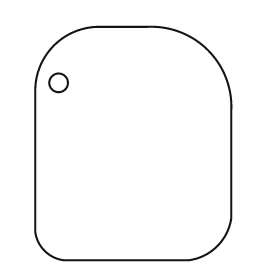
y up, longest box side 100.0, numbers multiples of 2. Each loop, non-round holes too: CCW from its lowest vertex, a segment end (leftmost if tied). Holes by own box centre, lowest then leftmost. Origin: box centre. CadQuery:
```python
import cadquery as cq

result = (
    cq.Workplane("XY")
    .moveTo(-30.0, -50.0)
    .lineTo(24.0, -50.0)
    .threePointArc((36.0, -44.0), (42.0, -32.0))
    .lineTo(42.0, 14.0)
    .threePointArc((32.0, 40.0), (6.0, 50.0))
    .lineTo(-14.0, 50.0)
    .threePointArc((-34.0, 42.0), (-42.0, 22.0))
    .lineTo(-42.0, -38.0)
    .threePointArc((-38.0, -46.0), (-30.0, -50.0))
    .close()
    .moveTo(-32.0, 26.0)
    .circle(4.0)
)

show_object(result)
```